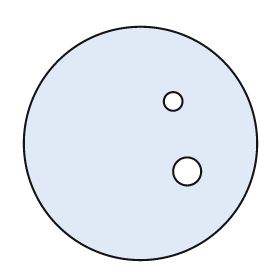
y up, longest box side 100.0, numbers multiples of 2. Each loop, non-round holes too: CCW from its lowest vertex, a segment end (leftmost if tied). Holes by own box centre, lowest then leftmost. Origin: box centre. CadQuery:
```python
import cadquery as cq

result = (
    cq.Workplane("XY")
    .moveTo(0.0, 0.0)
    .circle(50.0)
    .moveTo(20.0, -12.0)
    .circle(6.0)
    .moveTo(14.0, 18.0)
    .circle(4.0)
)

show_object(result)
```